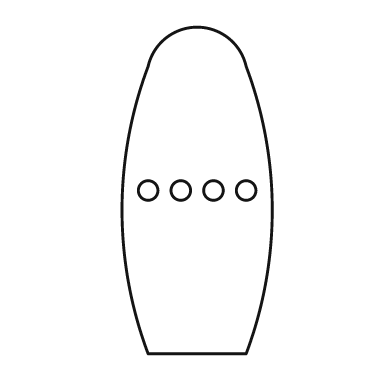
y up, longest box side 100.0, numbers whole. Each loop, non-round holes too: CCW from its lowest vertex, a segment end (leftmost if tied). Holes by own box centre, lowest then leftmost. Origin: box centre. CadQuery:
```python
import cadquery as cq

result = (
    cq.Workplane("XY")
    .moveTo(-15.0, -50.0)
    .lineTo(15.0, -50.0)
    .threePointArc((23.0, -6.0), (15.0, 38.0))
    .threePointArc((0.0, 50.0), (-15.0, 38.0))
    .threePointArc((-23.0, -6.0), (-15.0, -50.0))
    .close()
    .moveTo(-15.0, 0.0)
    .circle(3.0)
    .moveTo(-5.0, 0.0)
    .circle(3.0)
    .moveTo(5.0, 0.0)
    .circle(3.0)
    .moveTo(15.0, 0.0)
    .circle(3.0)
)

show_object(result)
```